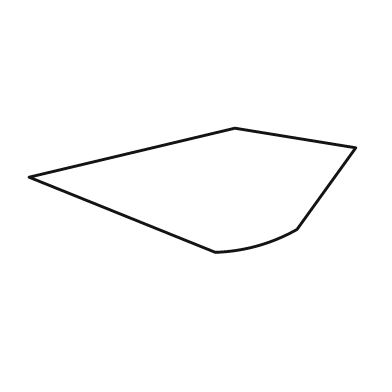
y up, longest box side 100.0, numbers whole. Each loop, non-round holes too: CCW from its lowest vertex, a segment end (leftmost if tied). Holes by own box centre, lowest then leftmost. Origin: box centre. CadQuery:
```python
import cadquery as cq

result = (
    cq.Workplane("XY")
    .moveTo(7.0, -19.0)
    .threePointArc((20.0, -17.0), (32.0, -12.0))
    .lineTo(50.0, 13.0)
    .lineTo(13.0, 19.0)
    .lineTo(-50.0, 4.0)
    .close()
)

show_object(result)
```